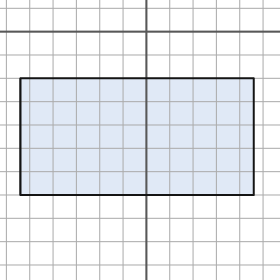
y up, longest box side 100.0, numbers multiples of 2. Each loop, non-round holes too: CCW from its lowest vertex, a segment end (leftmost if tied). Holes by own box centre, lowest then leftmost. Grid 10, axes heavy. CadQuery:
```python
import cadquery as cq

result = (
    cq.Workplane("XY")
    .moveTo(-54.0, -70.0)
    .lineTo(46.0, -70.0)
    .lineTo(46.0, -20.0)
    .lineTo(-54.0, -20.0)
    .close()
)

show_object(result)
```